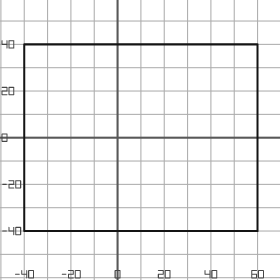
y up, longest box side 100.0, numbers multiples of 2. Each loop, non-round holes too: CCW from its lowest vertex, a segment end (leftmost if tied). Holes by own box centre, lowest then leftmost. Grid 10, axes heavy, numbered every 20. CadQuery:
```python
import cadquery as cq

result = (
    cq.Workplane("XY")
    .moveTo(-40.0, -40.0)
    .lineTo(60.0, -40.0)
    .lineTo(60.0, 40.0)
    .lineTo(-40.0, 40.0)
    .close()
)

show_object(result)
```